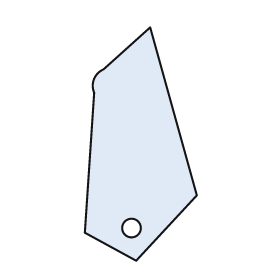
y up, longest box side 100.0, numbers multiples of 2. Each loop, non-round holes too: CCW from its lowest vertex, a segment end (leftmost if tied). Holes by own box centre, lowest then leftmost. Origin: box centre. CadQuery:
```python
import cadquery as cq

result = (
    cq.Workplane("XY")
    .moveTo(-2.0, -50.0)
    .lineTo(24.0, -22.0)
    .lineTo(4.0, 50.0)
    .lineTo(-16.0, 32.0)
    .threePointArc((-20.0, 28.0), (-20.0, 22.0))
    .lineTo(-24.0, -38.0)
    .close()
    .moveTo(-4.0, -36.0)
    .circle(4.0)
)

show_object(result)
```